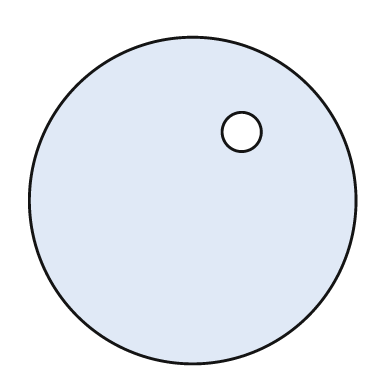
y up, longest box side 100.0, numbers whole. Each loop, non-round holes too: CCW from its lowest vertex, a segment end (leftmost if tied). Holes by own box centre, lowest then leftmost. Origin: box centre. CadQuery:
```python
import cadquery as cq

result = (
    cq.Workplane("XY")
    .moveTo(0.0, 0.0)
    .circle(50.0)
    .moveTo(15.0, 21.0)
    .circle(6.0)
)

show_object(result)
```